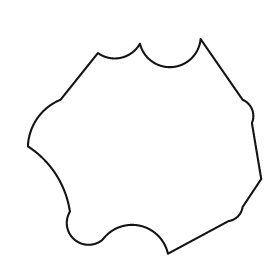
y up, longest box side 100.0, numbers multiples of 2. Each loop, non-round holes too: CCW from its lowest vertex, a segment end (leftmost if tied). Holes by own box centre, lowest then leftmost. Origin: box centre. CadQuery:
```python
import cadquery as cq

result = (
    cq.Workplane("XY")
    .moveTo(10.0, -46.0)
    .lineTo(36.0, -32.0)
    .threePointArc((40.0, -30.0), (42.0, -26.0))
    .lineTo(50.0, -14.0)
    .lineTo(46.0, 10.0)
    .threePointArc((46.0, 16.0), (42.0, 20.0))
    .lineTo(24.0, 46.0)
    .threePointArc((12.0, 34.0), (-2.0, 44.0))
    .threePointArc((-10.0, 38.0), (-20.0, 40.0))
    .lineTo(-36.0, 20.0)
    .threePointArc((-46.0, 12.0), (-50.0, 0.0))
    .threePointArc((-38.0, -12.0), (-32.0, -28.0))
    .threePointArc((-30.0, -40.0), (-18.0, -40.0))
    .threePointArc((-2.0, -34.0), (10.0, -46.0))
    .close()
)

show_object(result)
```